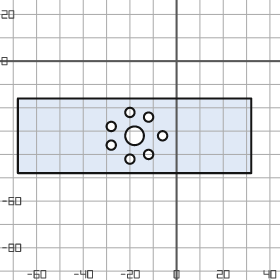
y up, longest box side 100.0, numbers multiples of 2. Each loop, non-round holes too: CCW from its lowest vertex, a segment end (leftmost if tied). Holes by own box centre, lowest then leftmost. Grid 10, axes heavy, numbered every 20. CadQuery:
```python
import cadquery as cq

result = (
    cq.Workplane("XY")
    .moveTo(-68.0, -48.0)
    .lineTo(32.0, -48.0)
    .lineTo(32.0, -16.0)
    .lineTo(-68.0, -16.0)
    .close()
    .moveTo(-20.0, -42.0)
    .circle(2.0)
    .moveTo(-12.0, -40.0)
    .circle(2.0)
    .moveTo(-28.0, -36.0)
    .circle(2.0)
    .moveTo(-18.0, -32.0)
    .circle(4.0)
    .moveTo(-6.0, -32.0)
    .circle(2.0)
    .moveTo(-28.0, -28.0)
    .circle(2.0)
    .moveTo(-12.0, -24.0)
    .circle(2.0)
    .moveTo(-20.0, -22.0)
    .circle(2.0)
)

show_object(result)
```